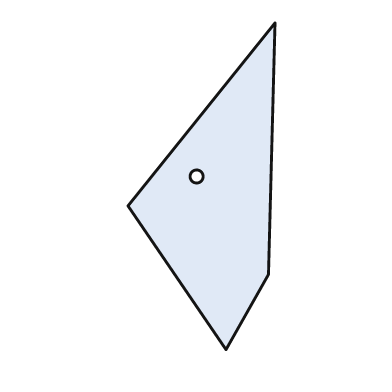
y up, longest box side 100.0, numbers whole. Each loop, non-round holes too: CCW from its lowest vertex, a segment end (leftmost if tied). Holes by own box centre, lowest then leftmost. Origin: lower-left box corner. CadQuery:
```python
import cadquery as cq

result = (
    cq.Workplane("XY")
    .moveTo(30.0, 0.0)
    .lineTo(43.0, 23.0)
    .lineTo(45.0, 100.0)
    .lineTo(0.0, 44.0)
    .close()
    .moveTo(21.0, 53.0)
    .circle(2.0)
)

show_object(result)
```